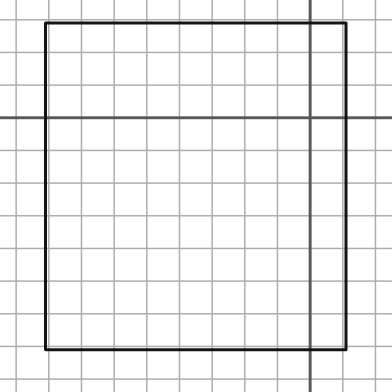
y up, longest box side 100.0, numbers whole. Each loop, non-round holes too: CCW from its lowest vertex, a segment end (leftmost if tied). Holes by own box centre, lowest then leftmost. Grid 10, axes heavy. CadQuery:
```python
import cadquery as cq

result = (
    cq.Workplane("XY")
    .moveTo(-81.0, -71.0)
    .lineTo(11.0, -71.0)
    .lineTo(11.0, 29.0)
    .lineTo(-81.0, 29.0)
    .close()
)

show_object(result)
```